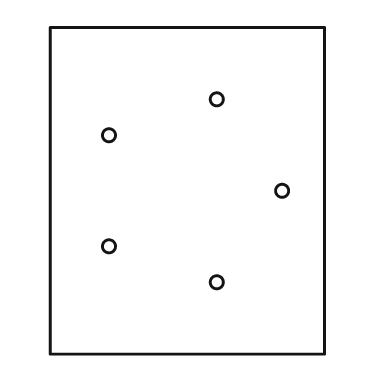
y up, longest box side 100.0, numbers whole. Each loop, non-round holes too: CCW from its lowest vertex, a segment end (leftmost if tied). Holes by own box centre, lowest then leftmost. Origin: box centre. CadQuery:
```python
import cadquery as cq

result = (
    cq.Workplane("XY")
    .moveTo(-42.0, -50.0)
    .lineTo(42.0, -50.0)
    .lineTo(42.0, 50.0)
    .lineTo(-42.0, 50.0)
    .close()
    .moveTo(9.0, -28.0)
    .circle(2.0)
    .moveTo(-24.0, -17.0)
    .circle(2.0)
    .moveTo(29.0, 0.0)
    .circle(2.0)
    .moveTo(-24.0, 17.0)
    .circle(2.0)
    .moveTo(9.0, 28.0)
    .circle(2.0)
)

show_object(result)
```